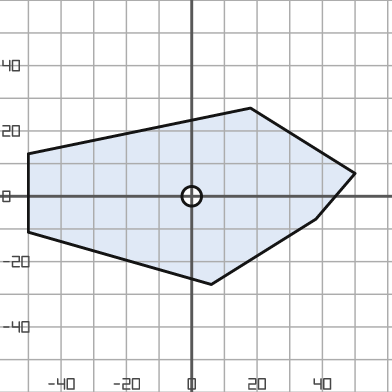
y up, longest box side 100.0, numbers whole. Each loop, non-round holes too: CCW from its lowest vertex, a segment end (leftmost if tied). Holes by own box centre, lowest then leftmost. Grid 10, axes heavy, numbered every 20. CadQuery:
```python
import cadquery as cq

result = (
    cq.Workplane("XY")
    .moveTo(6.0, -27.0)
    .lineTo(38.0, -7.0)
    .lineTo(50.0, 7.0)
    .lineTo(18.0, 27.0)
    .lineTo(-50.0, 13.0)
    .lineTo(-50.0, -11.0)
    .close()
    .moveTo(0.0, 0.0)
    .circle(3.0)
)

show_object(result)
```